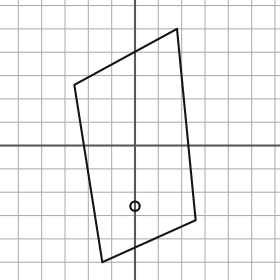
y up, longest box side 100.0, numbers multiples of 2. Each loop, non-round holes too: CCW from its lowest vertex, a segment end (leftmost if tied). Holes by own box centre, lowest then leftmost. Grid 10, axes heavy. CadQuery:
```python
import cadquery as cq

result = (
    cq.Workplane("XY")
    .moveTo(-14.0, -50.0)
    .lineTo(26.0, -32.0)
    .lineTo(18.0, 50.0)
    .lineTo(-26.0, 26.0)
    .close()
    .moveTo(0.0, -26.0)
    .circle(2.0)
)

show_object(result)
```